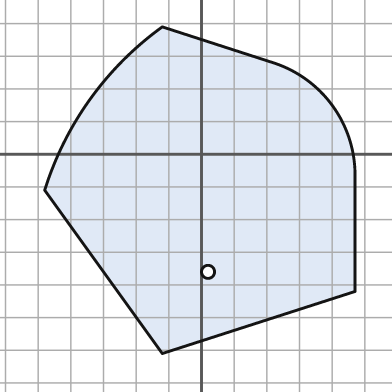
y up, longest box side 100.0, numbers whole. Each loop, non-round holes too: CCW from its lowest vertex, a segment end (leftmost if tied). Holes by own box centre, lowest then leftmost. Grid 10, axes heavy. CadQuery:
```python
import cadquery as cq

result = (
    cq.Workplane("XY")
    .moveTo(-12.0, -61.0)
    .lineTo(47.0, -42.0)
    .lineTo(47.0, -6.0)
    .threePointArc((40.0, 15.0), (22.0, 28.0))
    .lineTo(-12.0, 39.0)
    .threePointArc((-34.0, 17.0), (-48.0, -11.0))
    .close()
    .moveTo(2.0, -36.0)
    .circle(2.0)
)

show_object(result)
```